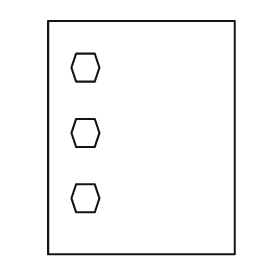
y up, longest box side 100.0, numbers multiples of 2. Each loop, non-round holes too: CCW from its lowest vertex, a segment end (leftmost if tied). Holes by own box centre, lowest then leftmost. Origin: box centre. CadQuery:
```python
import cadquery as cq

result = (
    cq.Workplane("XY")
    .moveTo(-40.0, -50.0)
    .lineTo(40.0, -50.0)
    .lineTo(40.0, 50.0)
    .lineTo(-40.0, 50.0)
    .close()
    .moveTo(-28.0, -32.0)
    .lineTo(-20.0, -32.0)
    .lineTo(-18.0, -26.0)
    .lineTo(-20.0, -20.0)
    .lineTo(-28.0, -20.0)
    .lineTo(-30.0, -26.0)
    .close()
    .moveTo(-28.0, -4.0)
    .lineTo(-20.0, -4.0)
    .lineTo(-18.0, 2.0)
    .lineTo(-20.0, 8.0)
    .lineTo(-28.0, 8.0)
    .lineTo(-30.0, 2.0)
    .close()
    .moveTo(-28.0, 24.0)
    .lineTo(-20.0, 24.0)
    .lineTo(-18.0, 30.0)
    .lineTo(-20.0, 36.0)
    .lineTo(-28.0, 36.0)
    .lineTo(-30.0, 30.0)
    .close()
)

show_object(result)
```